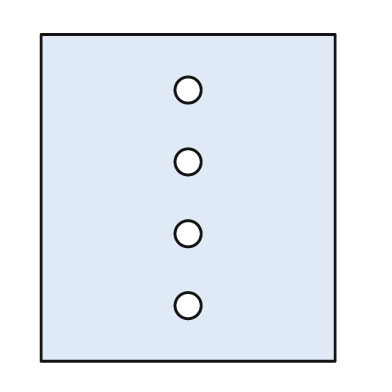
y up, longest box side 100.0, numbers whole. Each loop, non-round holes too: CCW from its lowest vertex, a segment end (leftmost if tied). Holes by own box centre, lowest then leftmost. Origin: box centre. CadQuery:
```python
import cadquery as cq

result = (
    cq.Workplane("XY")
    .moveTo(-45.0, -50.0)
    .lineTo(45.0, -50.0)
    .lineTo(45.0, 50.0)
    .lineTo(-45.0, 50.0)
    .close()
    .moveTo(0.0, -33.0)
    .circle(4.0)
    .moveTo(0.0, -11.0)
    .circle(4.0)
    .moveTo(0.0, 11.0)
    .circle(4.0)
    .moveTo(0.0, 33.0)
    .circle(4.0)
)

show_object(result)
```